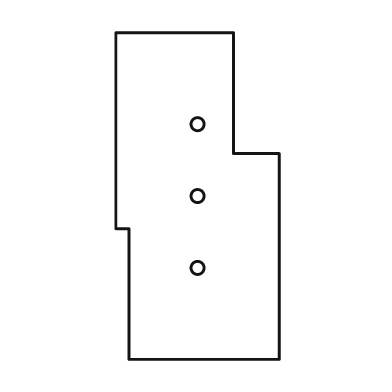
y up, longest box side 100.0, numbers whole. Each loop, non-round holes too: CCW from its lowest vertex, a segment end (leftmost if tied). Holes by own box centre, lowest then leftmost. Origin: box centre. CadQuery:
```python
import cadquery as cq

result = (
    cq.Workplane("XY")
    .moveTo(-21.0, -50.0)
    .lineTo(25.0, -50.0)
    .lineTo(25.0, 13.0)
    .lineTo(11.0, 13.0)
    .lineTo(11.0, 50.0)
    .lineTo(-25.0, 50.0)
    .lineTo(-25.0, -10.0)
    .lineTo(-21.0, -10.0)
    .close()
    .moveTo(0.0, -22.0)
    .circle(2.0)
    .moveTo(0.0, 0.0)
    .circle(2.0)
    .moveTo(0.0, 22.0)
    .circle(2.0)
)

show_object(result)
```